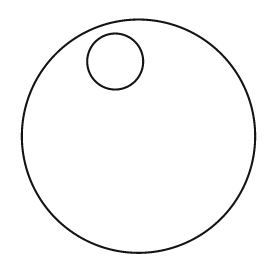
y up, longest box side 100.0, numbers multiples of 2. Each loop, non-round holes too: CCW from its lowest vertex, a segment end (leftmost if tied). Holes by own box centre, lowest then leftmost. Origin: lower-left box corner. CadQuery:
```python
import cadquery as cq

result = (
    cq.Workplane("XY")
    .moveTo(50.0, 50.0)
    .circle(50.0)
    .moveTo(40.0, 82.0)
    .circle(12.0)
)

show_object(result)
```